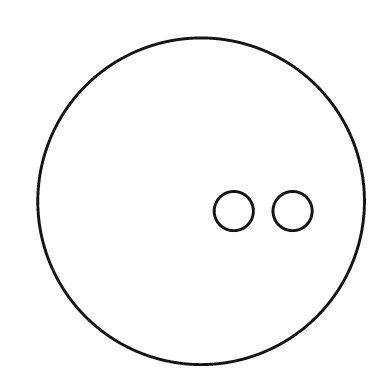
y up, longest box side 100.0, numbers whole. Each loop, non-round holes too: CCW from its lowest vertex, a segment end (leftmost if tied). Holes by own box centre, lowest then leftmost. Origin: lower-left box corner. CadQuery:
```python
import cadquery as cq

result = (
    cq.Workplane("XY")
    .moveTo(50.0, 50.0)
    .circle(50.0)
    .moveTo(60.0, 47.0)
    .circle(6.0)
    .moveTo(78.0, 47.0)
    .circle(6.0)
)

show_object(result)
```